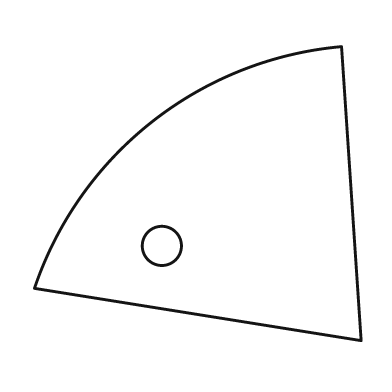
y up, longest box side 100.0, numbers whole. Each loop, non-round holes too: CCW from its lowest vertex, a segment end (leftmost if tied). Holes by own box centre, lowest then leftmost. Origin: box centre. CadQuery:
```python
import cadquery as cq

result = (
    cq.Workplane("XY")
    .moveTo(50.0, -45.0)
    .lineTo(44.0, 45.0)
    .threePointArc((-14.0, 22.0), (-50.0, -29.0))
    .close()
    .moveTo(-11.0, -16.0)
    .circle(6.0)
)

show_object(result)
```